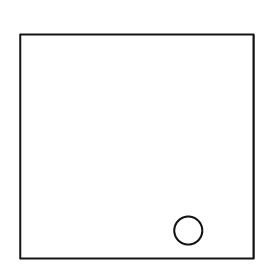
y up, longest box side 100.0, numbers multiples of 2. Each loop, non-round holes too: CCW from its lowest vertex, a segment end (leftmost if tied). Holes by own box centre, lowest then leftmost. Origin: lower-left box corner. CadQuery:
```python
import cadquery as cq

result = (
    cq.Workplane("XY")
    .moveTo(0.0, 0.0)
    .lineTo(100.0, 0.0)
    .lineTo(100.0, 96.0)
    .lineTo(0.0, 96.0)
    .close()
    .moveTo(72.0, 12.0)
    .circle(6.0)
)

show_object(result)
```